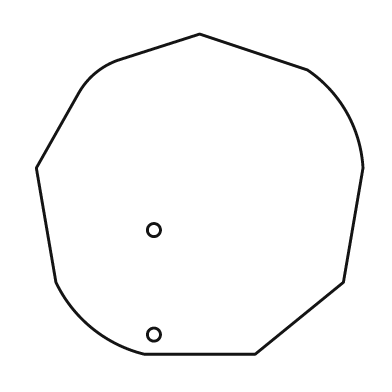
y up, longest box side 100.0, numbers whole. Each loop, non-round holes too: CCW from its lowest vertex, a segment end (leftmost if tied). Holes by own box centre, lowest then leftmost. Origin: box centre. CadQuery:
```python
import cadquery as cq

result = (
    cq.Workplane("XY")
    .moveTo(-17.0, -49.0)
    .lineTo(17.0, -49.0)
    .lineTo(44.0, -27.0)
    .lineTo(50.0, 8.0)
    .threePointArc((45.0, 25.0), (33.0, 38.0))
    .lineTo(0.0, 49.0)
    .lineTo(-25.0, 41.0)
    .threePointArc((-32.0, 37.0), (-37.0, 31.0))
    .lineTo(-50.0, 8.0)
    .lineTo(-44.0, -27.0)
    .threePointArc((-33.0, -41.0), (-17.0, -49.0))
    .close()
    .moveTo(-14.0, -43.0)
    .circle(2.0)
    .moveTo(-14.0, -11.0)
    .circle(2.0)
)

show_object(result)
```